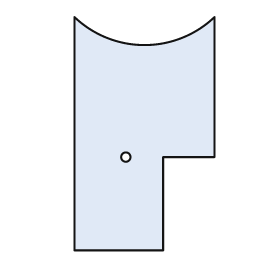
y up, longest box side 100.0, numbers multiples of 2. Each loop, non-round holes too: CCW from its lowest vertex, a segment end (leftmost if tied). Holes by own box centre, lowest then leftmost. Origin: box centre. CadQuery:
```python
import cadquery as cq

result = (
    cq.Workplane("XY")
    .moveTo(-30.0, -50.0)
    .lineTo(8.0, -50.0)
    .lineTo(8.0, -10.0)
    .lineTo(30.0, -10.0)
    .lineTo(30.0, 50.0)
    .threePointArc((0.0, 38.0), (-30.0, 50.0))
    .close()
    .moveTo(-8.0, -10.0)
    .circle(2.0)
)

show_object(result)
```